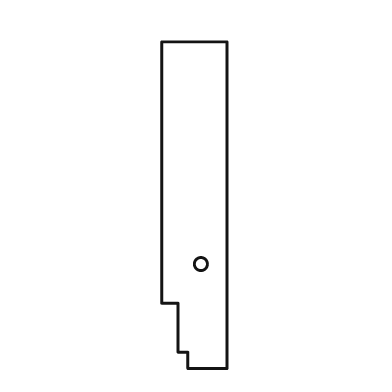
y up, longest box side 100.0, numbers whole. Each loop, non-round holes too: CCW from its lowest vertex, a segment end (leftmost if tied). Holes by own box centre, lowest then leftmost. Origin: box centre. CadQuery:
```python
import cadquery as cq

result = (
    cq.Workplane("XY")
    .moveTo(-2.0, -50.0)
    .lineTo(10.0, -50.0)
    .lineTo(10.0, 50.0)
    .lineTo(-10.0, 50.0)
    .lineTo(-10.0, -30.0)
    .lineTo(-5.0, -30.0)
    .lineTo(-5.0, -45.0)
    .lineTo(-2.0, -45.0)
    .close()
    .moveTo(2.0, -18.0)
    .circle(2.0)
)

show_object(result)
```